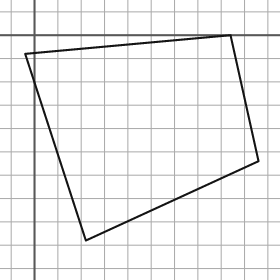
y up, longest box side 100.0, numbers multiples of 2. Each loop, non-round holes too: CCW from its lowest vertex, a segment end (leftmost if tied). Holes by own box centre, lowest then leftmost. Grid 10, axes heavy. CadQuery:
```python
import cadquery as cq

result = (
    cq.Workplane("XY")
    .moveTo(22.0, -88.0)
    .lineTo(96.0, -54.0)
    .lineTo(84.0, 0.0)
    .lineTo(-4.0, -8.0)
    .close()
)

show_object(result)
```